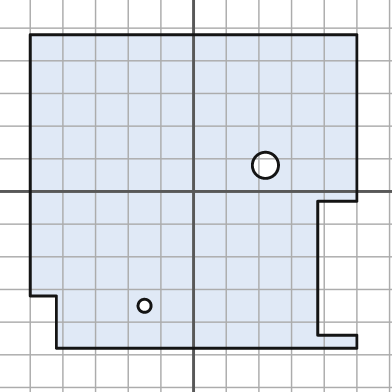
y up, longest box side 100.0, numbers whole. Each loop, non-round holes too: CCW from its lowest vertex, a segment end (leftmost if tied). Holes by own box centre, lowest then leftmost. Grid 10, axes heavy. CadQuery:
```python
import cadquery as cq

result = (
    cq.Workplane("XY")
    .moveTo(-42.0, -48.0)
    .lineTo(50.0, -48.0)
    .lineTo(50.0, -44.0)
    .lineTo(38.0, -44.0)
    .lineTo(38.0, -3.0)
    .lineTo(50.0, -3.0)
    .lineTo(50.0, 48.0)
    .lineTo(-50.0, 48.0)
    .lineTo(-50.0, -32.0)
    .lineTo(-42.0, -32.0)
    .close()
    .moveTo(-15.0, -35.0)
    .circle(2.0)
    .moveTo(22.0, 8.0)
    .circle(4.0)
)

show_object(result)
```